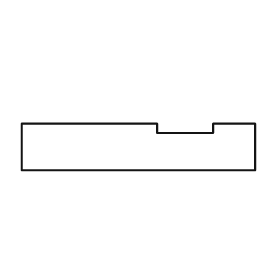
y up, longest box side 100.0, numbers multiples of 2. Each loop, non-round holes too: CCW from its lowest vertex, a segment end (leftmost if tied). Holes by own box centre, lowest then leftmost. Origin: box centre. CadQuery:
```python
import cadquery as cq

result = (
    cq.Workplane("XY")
    .moveTo(-50.0, -10.0)
    .lineTo(50.0, -10.0)
    .lineTo(50.0, 10.0)
    .lineTo(32.0, 10.0)
    .lineTo(32.0, 6.0)
    .lineTo(8.0, 6.0)
    .lineTo(8.0, 10.0)
    .lineTo(-50.0, 10.0)
    .close()
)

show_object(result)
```